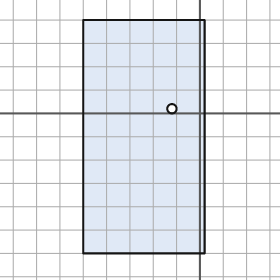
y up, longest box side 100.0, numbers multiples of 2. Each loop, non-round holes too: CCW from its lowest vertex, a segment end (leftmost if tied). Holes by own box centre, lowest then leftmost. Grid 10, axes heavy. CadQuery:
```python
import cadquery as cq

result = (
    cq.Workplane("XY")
    .moveTo(-50.0, -60.0)
    .lineTo(2.0, -60.0)
    .lineTo(2.0, 40.0)
    .lineTo(-50.0, 40.0)
    .close()
    .moveTo(-12.0, 2.0)
    .circle(2.0)
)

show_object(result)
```